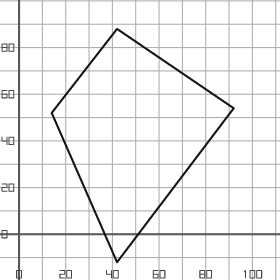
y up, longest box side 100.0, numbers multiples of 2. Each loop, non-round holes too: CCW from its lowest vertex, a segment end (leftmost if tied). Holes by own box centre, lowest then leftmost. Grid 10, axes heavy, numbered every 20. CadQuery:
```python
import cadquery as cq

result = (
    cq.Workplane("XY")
    .moveTo(42.0, -12.0)
    .lineTo(92.0, 54.0)
    .lineTo(42.0, 88.0)
    .lineTo(14.0, 52.0)
    .close()
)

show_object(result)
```